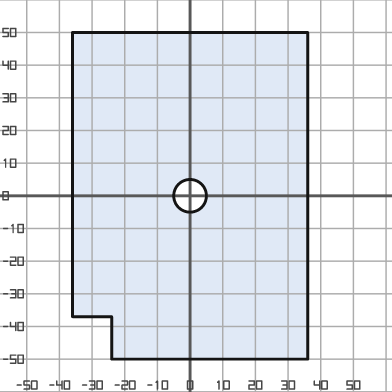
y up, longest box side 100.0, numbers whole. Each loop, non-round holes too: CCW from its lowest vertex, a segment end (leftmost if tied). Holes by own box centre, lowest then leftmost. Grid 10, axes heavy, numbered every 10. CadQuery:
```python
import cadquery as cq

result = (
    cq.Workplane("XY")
    .moveTo(-24.0, -50.0)
    .lineTo(36.0, -50.0)
    .lineTo(36.0, 50.0)
    .lineTo(-36.0, 50.0)
    .lineTo(-36.0, -37.0)
    .lineTo(-24.0, -37.0)
    .close()
    .moveTo(0.0, 0.0)
    .circle(5.0)
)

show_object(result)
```